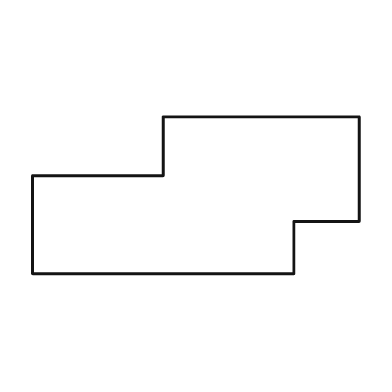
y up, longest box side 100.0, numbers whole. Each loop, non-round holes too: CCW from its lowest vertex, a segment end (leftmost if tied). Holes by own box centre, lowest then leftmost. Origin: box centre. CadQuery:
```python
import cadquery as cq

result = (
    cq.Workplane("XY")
    .moveTo(-50.0, -24.0)
    .lineTo(30.0, -24.0)
    .lineTo(30.0, -8.0)
    .lineTo(50.0, -8.0)
    .lineTo(50.0, 24.0)
    .lineTo(-10.0, 24.0)
    .lineTo(-10.0, 6.0)
    .lineTo(-50.0, 6.0)
    .close()
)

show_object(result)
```